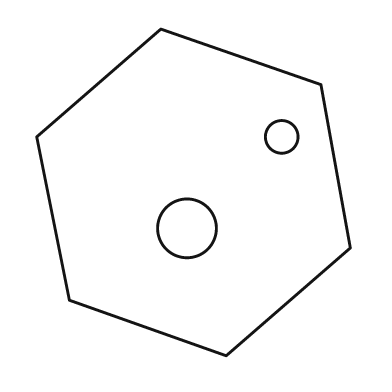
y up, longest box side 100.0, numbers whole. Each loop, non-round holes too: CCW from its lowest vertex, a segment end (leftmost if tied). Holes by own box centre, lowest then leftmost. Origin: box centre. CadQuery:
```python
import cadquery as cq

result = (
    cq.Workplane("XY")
    .moveTo(10.0, -50.0)
    .lineTo(48.0, -17.0)
    .lineTo(39.0, 33.0)
    .lineTo(-10.0, 50.0)
    .lineTo(-48.0, 17.0)
    .lineTo(-38.0, -33.0)
    .close()
    .moveTo(-2.0, -11.0)
    .circle(9.0)
    .moveTo(27.0, 17.0)
    .circle(5.0)
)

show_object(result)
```